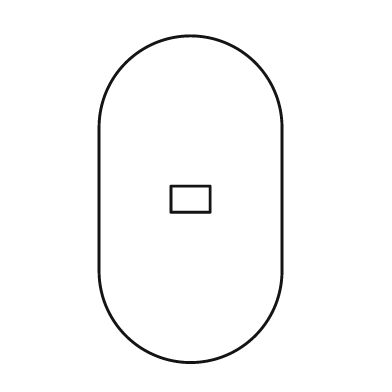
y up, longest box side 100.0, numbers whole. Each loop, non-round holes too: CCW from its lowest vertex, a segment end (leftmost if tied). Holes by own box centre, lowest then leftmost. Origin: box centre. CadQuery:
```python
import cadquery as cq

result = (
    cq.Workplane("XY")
    .moveTo(-28.0, -22.0)
    .threePointArc((0.0, -50.0), (28.0, -22.0))
    .lineTo(28.0, 22.0)
    .threePointArc((0.0, 50.0), (-28.0, 22.0))
    .close()
    .moveTo(-6.0, -4.0)
    .lineTo(6.0, -4.0)
    .lineTo(6.0, 4.0)
    .lineTo(-6.0, 4.0)
    .close()
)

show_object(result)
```